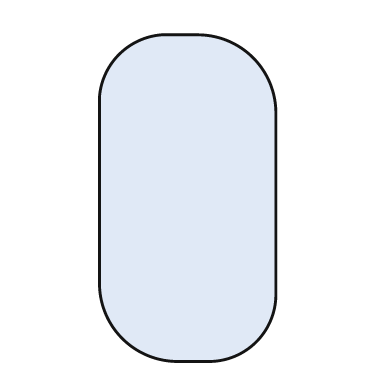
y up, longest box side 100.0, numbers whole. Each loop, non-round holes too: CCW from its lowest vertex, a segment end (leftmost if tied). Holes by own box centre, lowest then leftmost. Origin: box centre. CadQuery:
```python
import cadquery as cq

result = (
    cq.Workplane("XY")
    .moveTo(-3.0, -50.0)
    .lineTo(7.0, -50.0)
    .threePointArc((21.0, -44.0), (27.0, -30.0))
    .lineTo(27.0, 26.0)
    .threePointArc((20.0, 43.0), (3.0, 50.0))
    .lineTo(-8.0, 50.0)
    .threePointArc((-21.0, 44.0), (-27.0, 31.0))
    .lineTo(-27.0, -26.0)
    .threePointArc((-20.0, -43.0), (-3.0, -50.0))
    .close()
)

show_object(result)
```